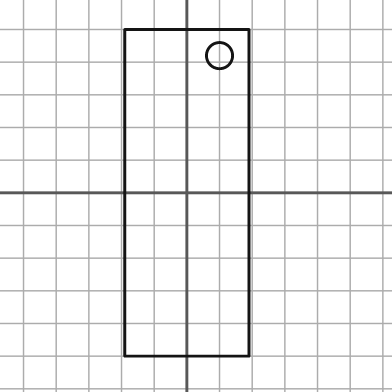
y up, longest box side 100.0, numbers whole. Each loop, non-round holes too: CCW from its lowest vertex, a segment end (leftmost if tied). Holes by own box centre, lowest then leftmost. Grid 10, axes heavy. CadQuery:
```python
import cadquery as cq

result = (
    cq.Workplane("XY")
    .moveTo(-19.0, -50.0)
    .lineTo(19.0, -50.0)
    .lineTo(19.0, 50.0)
    .lineTo(-19.0, 50.0)
    .close()
    .moveTo(10.0, 42.0)
    .circle(4.0)
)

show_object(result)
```